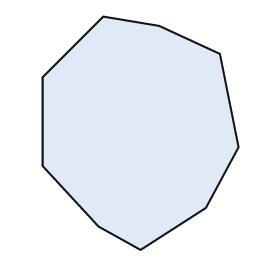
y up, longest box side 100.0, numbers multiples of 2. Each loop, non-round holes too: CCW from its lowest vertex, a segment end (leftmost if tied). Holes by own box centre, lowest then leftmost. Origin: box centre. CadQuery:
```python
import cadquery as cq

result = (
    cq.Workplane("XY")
    .moveTo(0.0, -50.0)
    .lineTo(28.0, -32.0)
    .lineTo(42.0, -6.0)
    .lineTo(34.0, 34.0)
    .lineTo(8.0, 46.0)
    .lineTo(-16.0, 50.0)
    .lineTo(-42.0, 24.0)
    .lineTo(-42.0, -14.0)
    .lineTo(-18.0, -40.0)
    .close()
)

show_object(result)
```